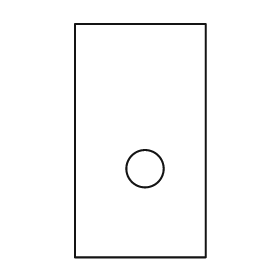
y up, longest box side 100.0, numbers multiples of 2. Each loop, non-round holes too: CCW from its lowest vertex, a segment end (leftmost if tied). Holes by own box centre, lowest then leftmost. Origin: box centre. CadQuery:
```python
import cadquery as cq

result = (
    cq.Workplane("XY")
    .moveTo(-28.0, -50.0)
    .lineTo(28.0, -50.0)
    .lineTo(28.0, 50.0)
    .lineTo(-28.0, 50.0)
    .close()
    .moveTo(2.0, -12.0)
    .circle(8.0)
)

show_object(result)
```